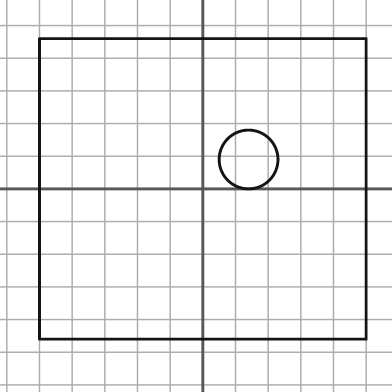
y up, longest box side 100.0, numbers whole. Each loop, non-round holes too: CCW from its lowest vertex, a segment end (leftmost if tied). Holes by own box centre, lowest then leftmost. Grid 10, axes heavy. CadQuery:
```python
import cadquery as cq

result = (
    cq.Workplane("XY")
    .moveTo(-50.0, -46.0)
    .lineTo(50.0, -46.0)
    .lineTo(50.0, 46.0)
    .lineTo(-50.0, 46.0)
    .close()
    .moveTo(14.0, 9.0)
    .circle(9.0)
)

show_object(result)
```